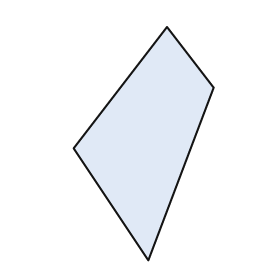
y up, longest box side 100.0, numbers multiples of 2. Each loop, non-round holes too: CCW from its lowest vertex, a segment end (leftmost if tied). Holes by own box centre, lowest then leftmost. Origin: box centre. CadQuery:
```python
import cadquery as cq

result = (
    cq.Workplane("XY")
    .moveTo(2.0, -50.0)
    .lineTo(30.0, 24.0)
    .lineTo(10.0, 50.0)
    .lineTo(-30.0, -2.0)
    .close()
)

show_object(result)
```